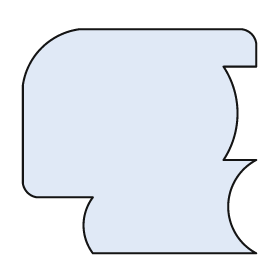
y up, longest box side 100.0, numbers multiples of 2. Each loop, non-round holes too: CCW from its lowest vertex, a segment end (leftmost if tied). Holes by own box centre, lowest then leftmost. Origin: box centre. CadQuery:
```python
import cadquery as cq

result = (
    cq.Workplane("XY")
    .moveTo(-20.0, -48.0)
    .lineTo(50.0, -48.0)
    .threePointArc((38.0, -28.0), (50.0, -8.0))
    .lineTo(36.0, -8.0)
    .threePointArc((42.0, 12.0), (36.0, 32.0))
    .lineTo(50.0, 32.0)
    .lineTo(50.0, 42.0)
    .threePointArc((48.0, 46.0), (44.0, 48.0))
    .lineTo(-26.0, 48.0)
    .threePointArc((-42.0, 40.0), (-50.0, 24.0))
    .lineTo(-50.0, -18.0)
    .threePointArc((-48.0, -22.0), (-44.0, -24.0))
    .lineTo(-20.0, -24.0)
    .threePointArc((-24.0, -36.0), (-20.0, -48.0))
    .close()
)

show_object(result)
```